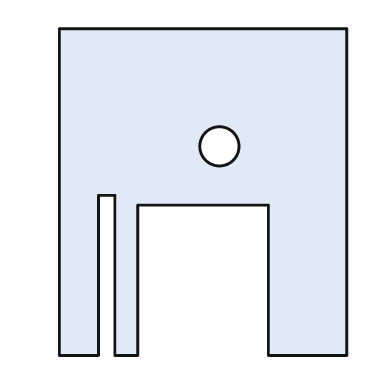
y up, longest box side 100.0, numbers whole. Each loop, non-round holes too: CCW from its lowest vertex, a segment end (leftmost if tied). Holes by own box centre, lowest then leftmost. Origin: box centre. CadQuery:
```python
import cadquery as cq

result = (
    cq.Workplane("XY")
    .moveTo(-44.0, -50.0)
    .lineTo(-32.0, -50.0)
    .lineTo(-32.0, -1.0)
    .lineTo(-27.0, -1.0)
    .lineTo(-27.0, -50.0)
    .lineTo(-20.0, -50.0)
    .lineTo(-20.0, -4.0)
    .lineTo(20.0, -4.0)
    .lineTo(20.0, -50.0)
    .lineTo(44.0, -50.0)
    .lineTo(44.0, 50.0)
    .lineTo(-44.0, 50.0)
    .close()
    .moveTo(5.0, 14.0)
    .circle(6.0)
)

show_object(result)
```